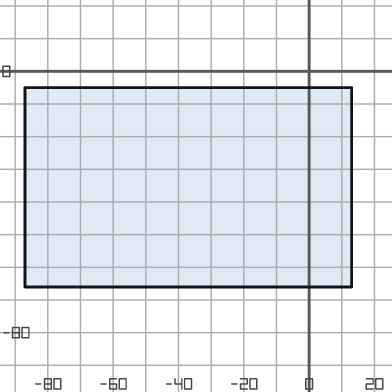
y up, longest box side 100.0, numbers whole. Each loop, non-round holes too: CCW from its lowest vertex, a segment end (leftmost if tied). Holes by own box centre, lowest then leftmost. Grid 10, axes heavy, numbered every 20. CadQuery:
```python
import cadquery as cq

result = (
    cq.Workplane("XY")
    .moveTo(-87.0, -66.0)
    .lineTo(13.0, -66.0)
    .lineTo(13.0, -5.0)
    .lineTo(-87.0, -5.0)
    .close()
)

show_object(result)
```